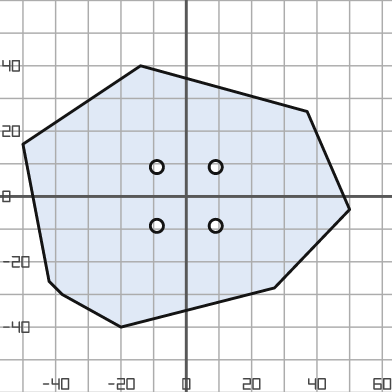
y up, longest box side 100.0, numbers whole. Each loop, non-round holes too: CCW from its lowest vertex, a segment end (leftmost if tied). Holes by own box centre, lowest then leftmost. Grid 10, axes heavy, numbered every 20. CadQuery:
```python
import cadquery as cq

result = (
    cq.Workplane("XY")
    .moveTo(-20.0, -40.0)
    .lineTo(27.0, -28.0)
    .lineTo(50.0, -4.0)
    .lineTo(37.0, 26.0)
    .lineTo(-14.0, 40.0)
    .lineTo(-50.0, 16.0)
    .lineTo(-42.0, -26.0)
    .lineTo(-38.0, -30.0)
    .close()
    .moveTo(-9.0, -9.0)
    .circle(2.0)
    .moveTo(9.0, -9.0)
    .circle(2.0)
    .moveTo(-9.0, 9.0)
    .circle(2.0)
    .moveTo(9.0, 9.0)
    .circle(2.0)
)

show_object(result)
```